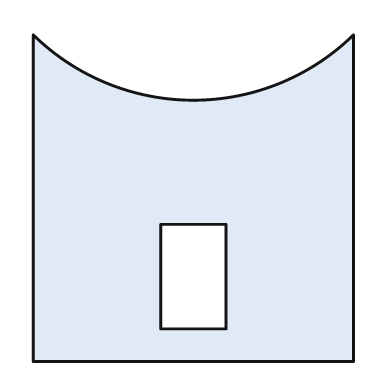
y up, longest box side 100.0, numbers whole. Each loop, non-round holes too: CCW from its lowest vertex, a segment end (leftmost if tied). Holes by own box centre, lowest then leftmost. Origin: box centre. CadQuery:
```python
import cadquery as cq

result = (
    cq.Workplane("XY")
    .moveTo(-49.0, -50.0)
    .lineTo(49.0, -50.0)
    .lineTo(49.0, 50.0)
    .threePointArc((0.0, 30.0), (-49.0, 50.0))
    .close()
    .moveTo(-10.0, -40.0)
    .lineTo(10.0, -40.0)
    .lineTo(10.0, -8.0)
    .lineTo(-10.0, -8.0)
    .close()
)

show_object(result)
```